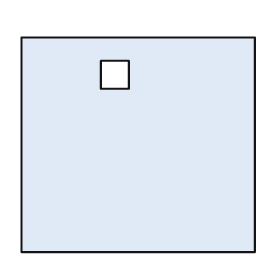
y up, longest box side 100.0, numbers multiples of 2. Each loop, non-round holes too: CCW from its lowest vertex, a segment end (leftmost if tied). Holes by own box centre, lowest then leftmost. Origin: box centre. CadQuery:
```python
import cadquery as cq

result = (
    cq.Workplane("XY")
    .moveTo(-50.0, -46.0)
    .lineTo(50.0, -46.0)
    .lineTo(50.0, 46.0)
    .lineTo(-50.0, 46.0)
    .close()
    .moveTo(-16.0, 24.0)
    .lineTo(-4.0, 24.0)
    .lineTo(-4.0, 36.0)
    .lineTo(-16.0, 36.0)
    .close()
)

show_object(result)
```